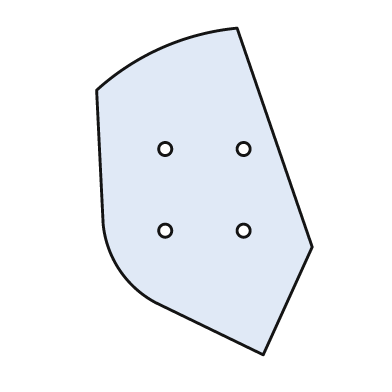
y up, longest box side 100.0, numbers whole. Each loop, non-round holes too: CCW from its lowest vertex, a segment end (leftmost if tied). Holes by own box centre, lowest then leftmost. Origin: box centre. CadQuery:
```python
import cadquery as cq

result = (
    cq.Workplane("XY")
    .moveTo(18.0, -50.0)
    .lineTo(33.0, -17.0)
    .lineTo(10.0, 50.0)
    .threePointArc((-13.0, 44.0), (-33.0, 31.0))
    .lineTo(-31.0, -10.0)
    .threePointArc((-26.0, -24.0), (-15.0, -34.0))
    .close()
    .moveTo(-12.0, -12.0)
    .circle(2.0)
    .moveTo(12.0, -12.0)
    .circle(2.0)
    .moveTo(-12.0, 13.0)
    .circle(2.0)
    .moveTo(12.0, 13.0)
    .circle(2.0)
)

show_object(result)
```